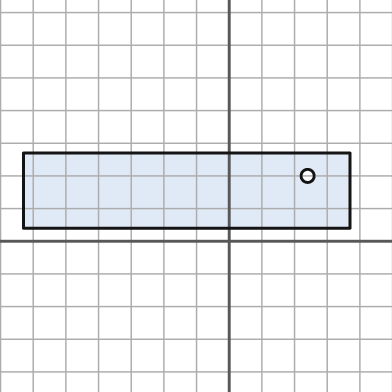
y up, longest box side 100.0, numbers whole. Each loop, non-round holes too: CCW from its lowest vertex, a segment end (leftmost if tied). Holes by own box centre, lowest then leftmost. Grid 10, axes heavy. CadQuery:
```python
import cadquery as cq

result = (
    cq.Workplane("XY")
    .moveTo(-63.0, 4.0)
    .lineTo(37.0, 4.0)
    .lineTo(37.0, 27.0)
    .lineTo(-63.0, 27.0)
    .close()
    .moveTo(24.0, 20.0)
    .circle(2.0)
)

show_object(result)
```